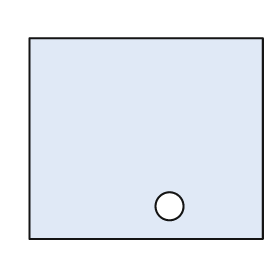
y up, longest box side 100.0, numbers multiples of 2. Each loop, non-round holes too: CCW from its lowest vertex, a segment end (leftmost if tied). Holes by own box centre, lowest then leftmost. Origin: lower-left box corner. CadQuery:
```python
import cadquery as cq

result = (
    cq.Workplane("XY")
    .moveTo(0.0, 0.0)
    .lineTo(100.0, 0.0)
    .lineTo(100.0, 86.0)
    .lineTo(0.0, 86.0)
    .close()
    .moveTo(60.0, 14.0)
    .circle(6.0)
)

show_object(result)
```